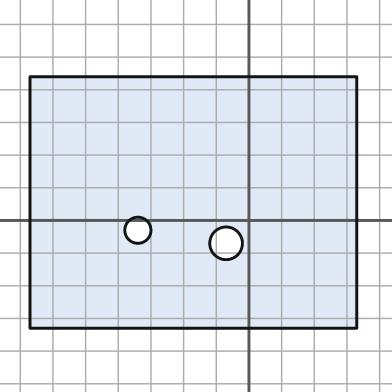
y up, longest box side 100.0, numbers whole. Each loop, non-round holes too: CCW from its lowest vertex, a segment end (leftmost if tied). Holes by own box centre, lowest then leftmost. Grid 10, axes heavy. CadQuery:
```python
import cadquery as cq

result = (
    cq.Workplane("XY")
    .moveTo(-67.0, -33.0)
    .lineTo(33.0, -33.0)
    .lineTo(33.0, 44.0)
    .lineTo(-67.0, 44.0)
    .close()
    .moveTo(-7.0, -7.0)
    .circle(5.0)
    .moveTo(-34.0, -3.0)
    .circle(4.0)
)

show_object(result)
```